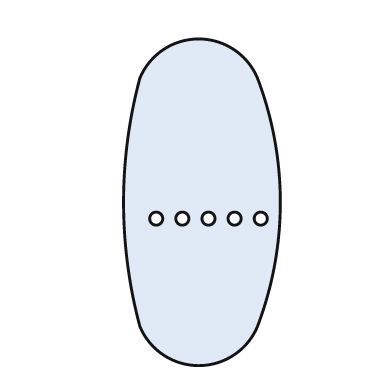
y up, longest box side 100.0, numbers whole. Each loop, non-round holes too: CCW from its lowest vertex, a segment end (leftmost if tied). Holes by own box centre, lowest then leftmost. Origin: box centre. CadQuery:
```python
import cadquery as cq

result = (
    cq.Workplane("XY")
    .moveTo(-19.0, -38.0)
    .threePointArc((-1.0, -50.0), (17.0, -38.0))
    .threePointArc((24.0, 0.0), (17.0, 38.0))
    .threePointArc((-1.0, 50.0), (-19.0, 38.0))
    .threePointArc((-24.0, 0.0), (-19.0, -38.0))
    .close()
    .moveTo(-14.0, -5.0)
    .circle(2.0)
    .moveTo(-6.0, -5.0)
    .circle(2.0)
    .moveTo(2.0, -5.0)
    .circle(2.0)
    .moveTo(10.0, -5.0)
    .circle(2.0)
    .moveTo(18.0, -5.0)
    .circle(2.0)
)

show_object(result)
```